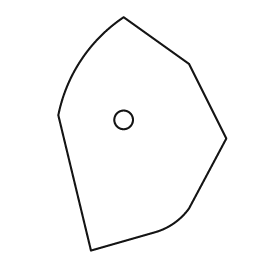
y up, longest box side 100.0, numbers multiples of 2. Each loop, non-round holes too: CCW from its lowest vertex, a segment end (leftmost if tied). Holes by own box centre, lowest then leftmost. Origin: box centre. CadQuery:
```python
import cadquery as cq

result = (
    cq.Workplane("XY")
    .moveTo(-22.0, -50.0)
    .lineTo(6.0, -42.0)
    .threePointArc((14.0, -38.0), (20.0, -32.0))
    .lineTo(36.0, -2.0)
    .lineTo(20.0, 30.0)
    .lineTo(-8.0, 50.0)
    .threePointArc((-26.0, 32.0), (-36.0, 8.0))
    .close()
    .moveTo(-8.0, 6.0)
    .circle(4.0)
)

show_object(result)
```